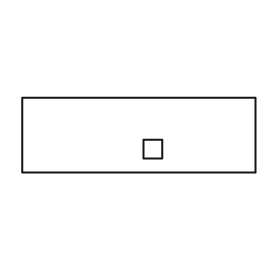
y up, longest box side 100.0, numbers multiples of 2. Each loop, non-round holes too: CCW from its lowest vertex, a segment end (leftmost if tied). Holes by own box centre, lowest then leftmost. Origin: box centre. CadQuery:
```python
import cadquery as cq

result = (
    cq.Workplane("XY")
    .moveTo(-50.0, -16.0)
    .lineTo(50.0, -16.0)
    .lineTo(50.0, 16.0)
    .lineTo(-50.0, 16.0)
    .close()
    .moveTo(2.0, -10.0)
    .lineTo(10.0, -10.0)
    .lineTo(10.0, -2.0)
    .lineTo(2.0, -2.0)
    .close()
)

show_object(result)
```